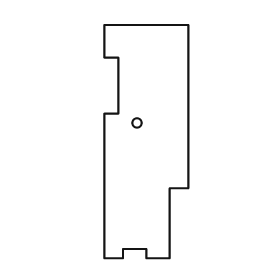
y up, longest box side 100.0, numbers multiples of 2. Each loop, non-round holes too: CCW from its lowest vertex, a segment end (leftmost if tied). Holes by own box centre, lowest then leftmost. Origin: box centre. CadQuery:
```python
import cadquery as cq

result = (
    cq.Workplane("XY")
    .moveTo(-18.0, -50.0)
    .lineTo(-10.0, -50.0)
    .lineTo(-10.0, -46.0)
    .lineTo(0.0, -46.0)
    .lineTo(0.0, -50.0)
    .lineTo(10.0, -50.0)
    .lineTo(10.0, -20.0)
    .lineTo(18.0, -20.0)
    .lineTo(18.0, 50.0)
    .lineTo(-18.0, 50.0)
    .lineTo(-18.0, 36.0)
    .lineTo(-12.0, 36.0)
    .lineTo(-12.0, 12.0)
    .lineTo(-18.0, 12.0)
    .close()
    .moveTo(-4.0, 8.0)
    .circle(2.0)
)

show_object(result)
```